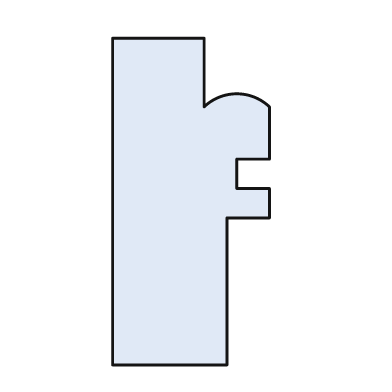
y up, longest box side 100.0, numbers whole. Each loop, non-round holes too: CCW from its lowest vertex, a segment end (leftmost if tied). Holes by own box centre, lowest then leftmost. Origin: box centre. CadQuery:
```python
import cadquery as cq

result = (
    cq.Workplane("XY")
    .moveTo(-24.0, -50.0)
    .lineTo(11.0, -50.0)
    .lineTo(11.0, -5.0)
    .lineTo(24.0, -5.0)
    .lineTo(24.0, 4.0)
    .lineTo(14.0, 4.0)
    .lineTo(14.0, 13.0)
    .lineTo(24.0, 13.0)
    .lineTo(24.0, 29.0)
    .threePointArc((14.0, 33.0), (4.0, 29.0))
    .lineTo(4.0, 50.0)
    .lineTo(-24.0, 50.0)
    .close()
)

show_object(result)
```